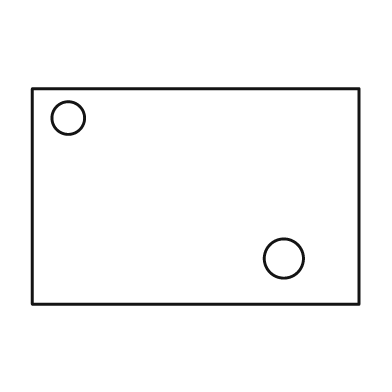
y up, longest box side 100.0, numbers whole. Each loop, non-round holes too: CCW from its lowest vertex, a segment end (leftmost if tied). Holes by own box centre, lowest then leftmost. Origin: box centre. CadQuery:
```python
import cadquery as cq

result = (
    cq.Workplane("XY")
    .moveTo(-50.0, -33.0)
    .lineTo(50.0, -33.0)
    .lineTo(50.0, 33.0)
    .lineTo(-50.0, 33.0)
    .close()
    .moveTo(27.0, -19.0)
    .circle(6.0)
    .moveTo(-39.0, 24.0)
    .circle(5.0)
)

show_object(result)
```